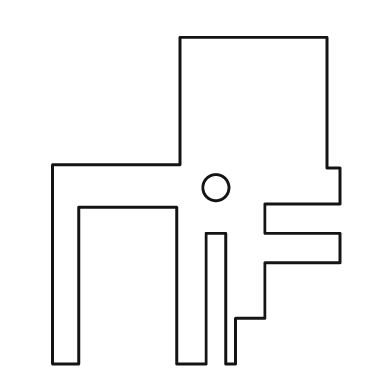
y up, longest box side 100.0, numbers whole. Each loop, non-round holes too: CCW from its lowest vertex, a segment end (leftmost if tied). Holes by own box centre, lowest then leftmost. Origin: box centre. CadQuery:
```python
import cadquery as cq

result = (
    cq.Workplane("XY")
    .moveTo(-44.0, -50.0)
    .lineTo(-36.0, -50.0)
    .lineTo(-36.0, -2.0)
    .lineTo(-6.0, -2.0)
    .lineTo(-6.0, -50.0)
    .lineTo(3.0, -50.0)
    .lineTo(3.0, -10.0)
    .lineTo(9.0, -10.0)
    .lineTo(9.0, -50.0)
    .lineTo(12.0, -50.0)
    .lineTo(12.0, -36.0)
    .lineTo(21.0, -36.0)
    .lineTo(21.0, -19.0)
    .lineTo(44.0, -19.0)
    .lineTo(44.0, -10.0)
    .lineTo(21.0, -10.0)
    .lineTo(21.0, -1.0)
    .lineTo(44.0, -1.0)
    .lineTo(44.0, 10.0)
    .lineTo(40.0, 10.0)
    .lineTo(40.0, 50.0)
    .lineTo(-5.0, 50.0)
    .lineTo(-5.0, 11.0)
    .lineTo(-44.0, 11.0)
    .close()
    .moveTo(6.0, 4.0)
    .circle(4.0)
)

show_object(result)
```